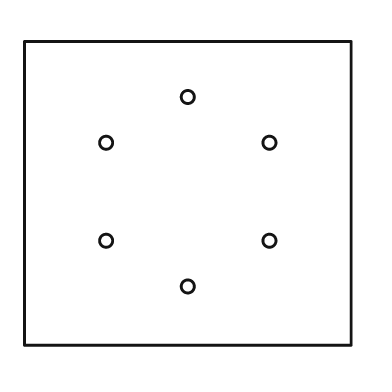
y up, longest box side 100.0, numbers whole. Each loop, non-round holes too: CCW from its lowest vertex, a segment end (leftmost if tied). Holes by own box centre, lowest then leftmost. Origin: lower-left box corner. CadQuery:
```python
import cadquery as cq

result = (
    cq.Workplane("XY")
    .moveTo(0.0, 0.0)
    .lineTo(100.0, 0.0)
    .lineTo(100.0, 93.0)
    .lineTo(0.0, 93.0)
    .close()
    .moveTo(50.0, 18.0)
    .circle(2.0)
    .moveTo(25.0, 32.0)
    .circle(2.0)
    .moveTo(75.0, 32.0)
    .circle(2.0)
    .moveTo(25.0, 62.0)
    .circle(2.0)
    .moveTo(75.0, 62.0)
    .circle(2.0)
    .moveTo(50.0, 76.0)
    .circle(2.0)
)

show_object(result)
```